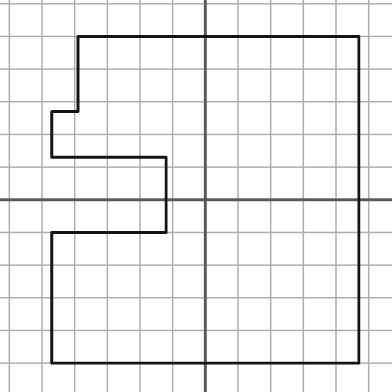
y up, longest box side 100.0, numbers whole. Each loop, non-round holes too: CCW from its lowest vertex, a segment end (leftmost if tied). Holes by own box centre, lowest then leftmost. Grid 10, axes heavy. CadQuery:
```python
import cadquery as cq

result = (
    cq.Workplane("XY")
    .moveTo(-47.0, -50.0)
    .lineTo(47.0, -50.0)
    .lineTo(47.0, 50.0)
    .lineTo(-39.0, 50.0)
    .lineTo(-39.0, 27.0)
    .lineTo(-47.0, 27.0)
    .lineTo(-47.0, 13.0)
    .lineTo(-12.0, 13.0)
    .lineTo(-12.0, -10.0)
    .lineTo(-47.0, -10.0)
    .close()
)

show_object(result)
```